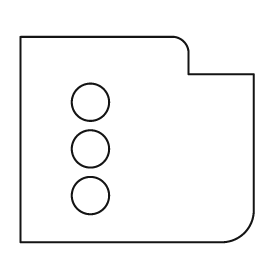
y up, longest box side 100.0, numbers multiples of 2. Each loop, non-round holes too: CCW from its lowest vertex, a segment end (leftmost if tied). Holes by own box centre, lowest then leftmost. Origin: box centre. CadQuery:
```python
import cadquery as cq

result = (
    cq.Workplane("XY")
    .moveTo(-50.0, -44.0)
    .lineTo(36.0, -44.0)
    .threePointArc((46.0, -40.0), (50.0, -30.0))
    .lineTo(50.0, 28.0)
    .lineTo(22.0, 28.0)
    .lineTo(22.0, 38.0)
    .threePointArc((20.0, 42.0), (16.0, 44.0))
    .lineTo(-50.0, 44.0)
    .close()
    .moveTo(-20.0, -24.0)
    .circle(8.0)
    .moveTo(-20.0, -4.0)
    .circle(8.0)
    .moveTo(-20.0, 16.0)
    .circle(8.0)
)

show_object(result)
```